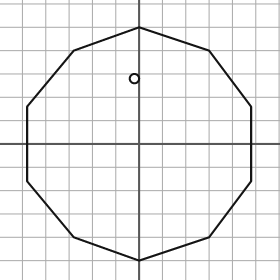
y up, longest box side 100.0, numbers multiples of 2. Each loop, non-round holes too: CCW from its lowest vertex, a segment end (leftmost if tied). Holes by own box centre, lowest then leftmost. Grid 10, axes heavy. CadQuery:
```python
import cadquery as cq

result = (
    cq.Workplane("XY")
    .moveTo(0.0, -50.0)
    .lineTo(30.0, -40.0)
    .lineTo(48.0, -16.0)
    .lineTo(48.0, 16.0)
    .lineTo(30.0, 40.0)
    .lineTo(0.0, 50.0)
    .lineTo(-28.0, 40.0)
    .lineTo(-48.0, 16.0)
    .lineTo(-48.0, -16.0)
    .lineTo(-28.0, -40.0)
    .close()
    .moveTo(-2.0, 28.0)
    .circle(2.0)
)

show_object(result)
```